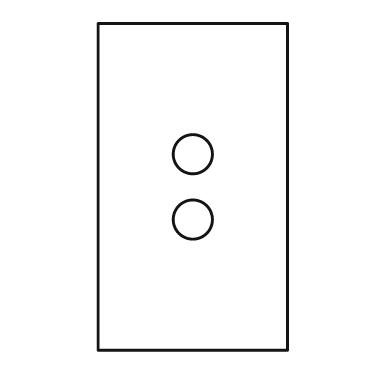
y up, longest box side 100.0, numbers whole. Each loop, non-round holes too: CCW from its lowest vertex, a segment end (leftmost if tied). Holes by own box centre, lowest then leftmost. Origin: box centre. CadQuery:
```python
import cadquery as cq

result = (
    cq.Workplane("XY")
    .moveTo(-29.0, -50.0)
    .lineTo(29.0, -50.0)
    .lineTo(29.0, 50.0)
    .lineTo(-29.0, 50.0)
    .close()
    .moveTo(0.0, -10.0)
    .circle(6.0)
    .moveTo(0.0, 10.0)
    .circle(6.0)
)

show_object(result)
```